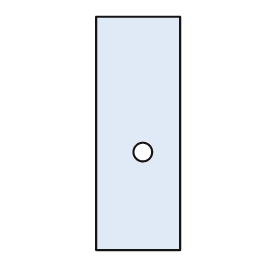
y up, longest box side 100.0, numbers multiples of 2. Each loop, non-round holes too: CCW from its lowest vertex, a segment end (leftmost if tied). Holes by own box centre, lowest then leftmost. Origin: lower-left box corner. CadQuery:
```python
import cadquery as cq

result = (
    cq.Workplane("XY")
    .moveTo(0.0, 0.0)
    .lineTo(36.0, 0.0)
    .lineTo(36.0, 100.0)
    .lineTo(0.0, 100.0)
    .close()
    .moveTo(20.0, 42.0)
    .circle(4.0)
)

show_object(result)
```